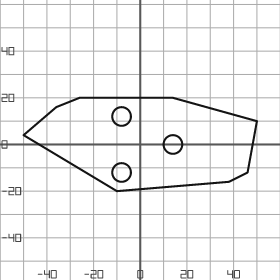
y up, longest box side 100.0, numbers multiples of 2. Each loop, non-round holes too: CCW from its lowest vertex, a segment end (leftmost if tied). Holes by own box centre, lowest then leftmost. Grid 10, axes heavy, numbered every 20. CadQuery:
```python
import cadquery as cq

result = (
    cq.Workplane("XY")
    .moveTo(-10.0, -20.0)
    .lineTo(38.0, -16.0)
    .lineTo(46.0, -12.0)
    .lineTo(50.0, 10.0)
    .lineTo(14.0, 20.0)
    .lineTo(-26.0, 20.0)
    .lineTo(-36.0, 16.0)
    .lineTo(-50.0, 4.0)
    .close()
    .moveTo(-8.0, -12.0)
    .circle(4.0)
    .moveTo(14.0, 0.0)
    .circle(4.0)
    .moveTo(-8.0, 12.0)
    .circle(4.0)
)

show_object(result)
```